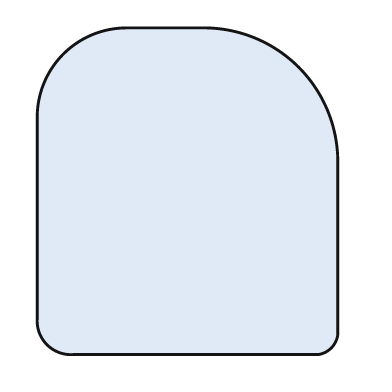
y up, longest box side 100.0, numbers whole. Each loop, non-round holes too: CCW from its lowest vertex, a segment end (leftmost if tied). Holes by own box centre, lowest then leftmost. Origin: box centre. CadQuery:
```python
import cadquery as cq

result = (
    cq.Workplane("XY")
    .moveTo(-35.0, -50.0)
    .lineTo(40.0, -50.0)
    .threePointArc((44.0, -48.0), (46.0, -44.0))
    .lineTo(46.0, 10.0)
    .threePointArc((34.0, 38.0), (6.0, 50.0))
    .lineTo(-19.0, 50.0)
    .threePointArc((-38.0, 42.0), (-46.0, 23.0))
    .lineTo(-46.0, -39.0)
    .threePointArc((-43.0, -47.0), (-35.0, -50.0))
    .close()
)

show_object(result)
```